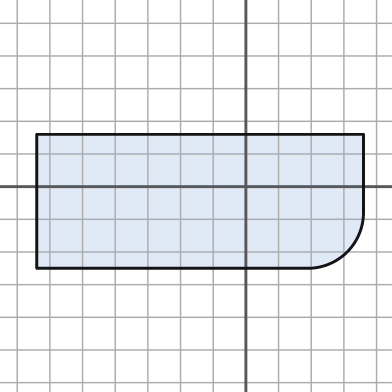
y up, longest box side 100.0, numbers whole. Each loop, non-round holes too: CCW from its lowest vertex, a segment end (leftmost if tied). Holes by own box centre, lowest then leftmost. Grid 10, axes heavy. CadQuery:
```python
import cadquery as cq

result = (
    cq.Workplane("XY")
    .moveTo(-64.0, -25.0)
    .lineTo(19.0, -25.0)
    .threePointArc((31.0, -20.0), (36.0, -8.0))
    .lineTo(36.0, 16.0)
    .lineTo(-64.0, 16.0)
    .close()
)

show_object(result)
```